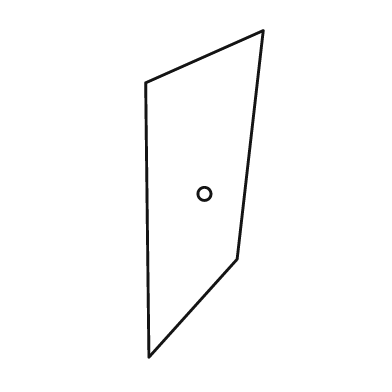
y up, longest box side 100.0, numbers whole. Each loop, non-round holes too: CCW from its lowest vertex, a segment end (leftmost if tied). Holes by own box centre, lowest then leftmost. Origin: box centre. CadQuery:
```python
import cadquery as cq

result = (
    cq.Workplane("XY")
    .moveTo(-17.0, -50.0)
    .lineTo(10.0, -20.0)
    .lineTo(18.0, 50.0)
    .lineTo(-18.0, 34.0)
    .close()
    .moveTo(0.0, 0.0)
    .circle(2.0)
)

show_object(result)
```